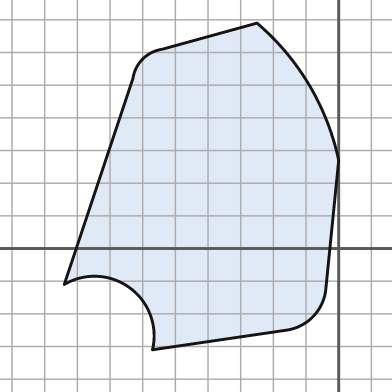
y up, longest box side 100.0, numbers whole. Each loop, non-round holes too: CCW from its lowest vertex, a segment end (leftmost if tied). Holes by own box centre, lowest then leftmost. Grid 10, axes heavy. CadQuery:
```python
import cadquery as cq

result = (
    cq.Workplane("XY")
    .moveTo(-57.0, -31.0)
    .lineTo(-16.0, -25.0)
    .threePointArc((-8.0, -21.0), (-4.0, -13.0))
    .lineTo(0.0, 27.0)
    .threePointArc((-9.0, 50.0), (-25.0, 69.0))
    .lineTo(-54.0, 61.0)
    .threePointArc((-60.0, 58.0), (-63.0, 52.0))
    .lineTo(-84.0, -11.0)
    .threePointArc((-64.0, -12.0), (-57.0, -31.0))
    .close()
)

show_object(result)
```